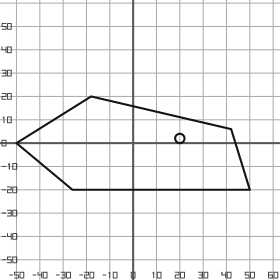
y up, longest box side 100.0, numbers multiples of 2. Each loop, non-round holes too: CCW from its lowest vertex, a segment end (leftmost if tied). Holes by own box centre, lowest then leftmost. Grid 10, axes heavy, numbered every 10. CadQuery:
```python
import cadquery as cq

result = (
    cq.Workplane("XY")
    .moveTo(-26.0, -20.0)
    .lineTo(50.0, -20.0)
    .lineTo(42.0, 6.0)
    .lineTo(-18.0, 20.0)
    .lineTo(-50.0, 0.0)
    .close()
    .moveTo(20.0, 2.0)
    .circle(2.0)
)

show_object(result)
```